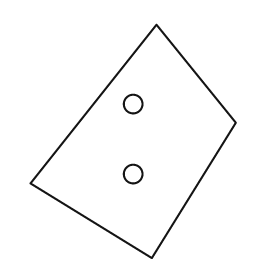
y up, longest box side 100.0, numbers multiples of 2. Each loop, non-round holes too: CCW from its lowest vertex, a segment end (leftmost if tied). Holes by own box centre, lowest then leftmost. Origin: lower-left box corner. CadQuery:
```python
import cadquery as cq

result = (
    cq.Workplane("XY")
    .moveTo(52.0, 0.0)
    .lineTo(88.0, 58.0)
    .lineTo(54.0, 100.0)
    .lineTo(0.0, 32.0)
    .close()
    .moveTo(44.0, 36.0)
    .circle(4.0)
    .moveTo(44.0, 66.0)
    .circle(4.0)
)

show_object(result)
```